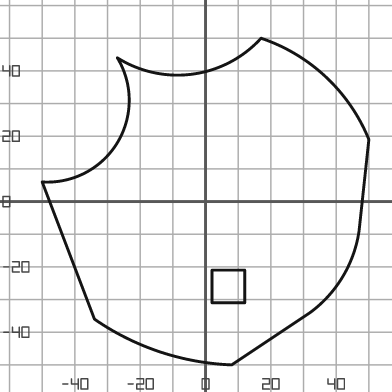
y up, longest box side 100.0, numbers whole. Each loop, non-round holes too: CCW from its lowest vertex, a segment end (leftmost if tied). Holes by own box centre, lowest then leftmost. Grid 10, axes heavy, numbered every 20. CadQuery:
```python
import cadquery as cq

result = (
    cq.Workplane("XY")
    .moveTo(8.0, -50.0)
    .lineTo(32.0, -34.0)
    .threePointArc((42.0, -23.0), (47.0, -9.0))
    .lineTo(50.0, 19.0)
    .threePointArc((37.0, 38.0), (17.0, 50.0))
    .threePointArc((-4.0, 39.0), (-27.0, 44.0))
    .threePointArc((-27.0, 18.0), (-50.0, 6.0))
    .lineTo(-34.0, -36.0)
    .threePointArc((-14.0, -46.0), (8.0, -50.0))
    .close()
    .moveTo(2.0, -31.0)
    .lineTo(12.0, -31.0)
    .lineTo(12.0, -21.0)
    .lineTo(2.0, -21.0)
    .close()
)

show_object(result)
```